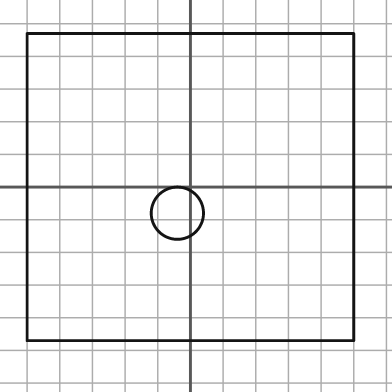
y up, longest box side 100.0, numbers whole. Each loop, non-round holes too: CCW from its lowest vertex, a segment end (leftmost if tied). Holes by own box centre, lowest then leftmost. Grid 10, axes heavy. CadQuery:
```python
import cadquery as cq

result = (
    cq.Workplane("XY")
    .moveTo(-50.0, -47.0)
    .lineTo(50.0, -47.0)
    .lineTo(50.0, 47.0)
    .lineTo(-50.0, 47.0)
    .close()
    .moveTo(-4.0, -8.0)
    .circle(8.0)
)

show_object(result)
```